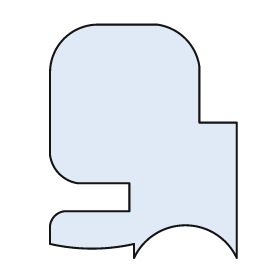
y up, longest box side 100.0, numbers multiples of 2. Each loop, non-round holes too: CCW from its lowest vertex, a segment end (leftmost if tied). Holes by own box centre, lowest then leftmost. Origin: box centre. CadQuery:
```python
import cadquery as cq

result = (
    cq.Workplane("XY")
    .moveTo(-4.0, -50.0)
    .threePointArc((18.0, -36.0), (40.0, -50.0))
    .lineTo(40.0, 8.0)
    .lineTo(24.0, 8.0)
    .lineTo(24.0, 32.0)
    .threePointArc((18.0, 44.0), (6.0, 50.0))
    .lineTo(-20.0, 50.0)
    .threePointArc((-34.0, 44.0), (-40.0, 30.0))
    .lineTo(-40.0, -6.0)
    .threePointArc((-36.0, -14.0), (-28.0, -18.0))
    .lineTo(-6.0, -18.0)
    .lineTo(-6.0, -30.0)
    .lineTo(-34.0, -30.0)
    .threePointArc((-38.0, -32.0), (-40.0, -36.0))
    .lineTo(-40.0, -44.0)
    .threePointArc((-22.0, -46.0), (-4.0, -44.0))
    .close()
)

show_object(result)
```